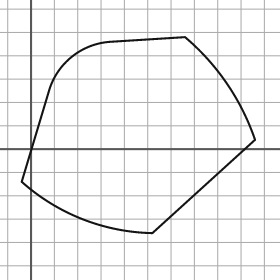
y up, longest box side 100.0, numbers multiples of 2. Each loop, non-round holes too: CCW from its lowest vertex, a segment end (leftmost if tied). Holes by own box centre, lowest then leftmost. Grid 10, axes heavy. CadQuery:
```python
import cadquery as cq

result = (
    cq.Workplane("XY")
    .moveTo(52.0, -36.0)
    .lineTo(96.0, 4.0)
    .threePointArc((84.0, 28.0), (66.0, 48.0))
    .lineTo(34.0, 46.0)
    .threePointArc((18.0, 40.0), (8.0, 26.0))
    .lineTo(-4.0, -14.0)
    .threePointArc((22.0, -30.0), (52.0, -36.0))
    .close()
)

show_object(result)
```